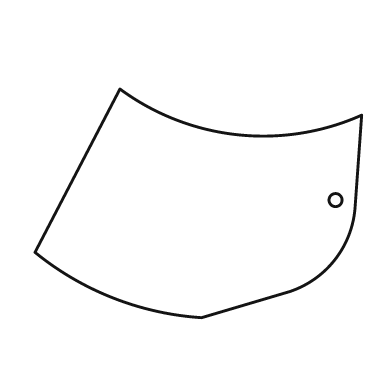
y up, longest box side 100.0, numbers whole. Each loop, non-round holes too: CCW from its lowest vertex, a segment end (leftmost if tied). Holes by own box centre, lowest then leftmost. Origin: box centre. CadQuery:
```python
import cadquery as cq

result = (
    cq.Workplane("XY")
    .moveTo(1.0, -35.0)
    .lineTo(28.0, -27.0)
    .threePointArc((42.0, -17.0), (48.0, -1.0))
    .lineTo(50.0, 27.0)
    .threePointArc((12.0, 21.0), (-24.0, 35.0))
    .lineTo(-50.0, -15.0)
    .threePointArc((-26.0, -29.0), (1.0, -35.0))
    .close()
    .moveTo(42.0, 1.0)
    .circle(2.0)
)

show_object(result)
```